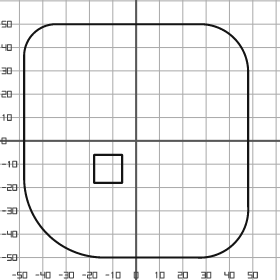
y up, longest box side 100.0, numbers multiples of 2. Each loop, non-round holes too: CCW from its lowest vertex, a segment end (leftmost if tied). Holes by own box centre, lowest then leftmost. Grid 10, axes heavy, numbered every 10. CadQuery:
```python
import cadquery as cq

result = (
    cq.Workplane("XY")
    .moveTo(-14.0, -50.0)
    .lineTo(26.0, -50.0)
    .threePointArc((42.0, -44.0), (48.0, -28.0))
    .lineTo(48.0, 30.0)
    .threePointArc((42.0, 44.0), (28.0, 50.0))
    .lineTo(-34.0, 50.0)
    .threePointArc((-44.0, 46.0), (-48.0, 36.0))
    .lineTo(-48.0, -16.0)
    .threePointArc((-38.0, -40.0), (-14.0, -50.0))
    .close()
    .moveTo(-18.0, -18.0)
    .lineTo(-6.0, -18.0)
    .lineTo(-6.0, -6.0)
    .lineTo(-18.0, -6.0)
    .close()
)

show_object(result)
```